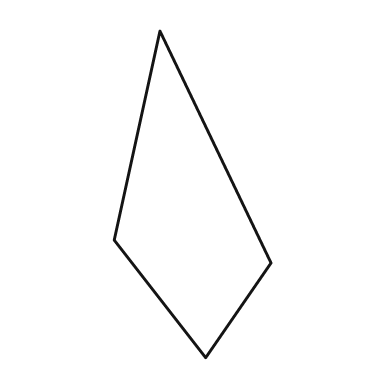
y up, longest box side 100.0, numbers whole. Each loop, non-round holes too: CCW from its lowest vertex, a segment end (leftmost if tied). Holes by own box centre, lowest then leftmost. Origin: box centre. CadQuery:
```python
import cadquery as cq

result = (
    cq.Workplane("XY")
    .moveTo(4.0, -50.0)
    .lineTo(24.0, -21.0)
    .lineTo(-10.0, 50.0)
    .lineTo(-24.0, -14.0)
    .close()
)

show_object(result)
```